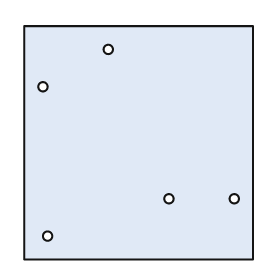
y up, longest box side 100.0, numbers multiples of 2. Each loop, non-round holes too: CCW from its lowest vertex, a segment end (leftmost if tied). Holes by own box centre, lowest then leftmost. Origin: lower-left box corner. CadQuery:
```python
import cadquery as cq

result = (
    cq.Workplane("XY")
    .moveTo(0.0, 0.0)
    .lineTo(98.0, 0.0)
    .lineTo(98.0, 100.0)
    .lineTo(0.0, 100.0)
    .close()
    .moveTo(10.0, 10.0)
    .circle(2.0)
    .moveTo(62.0, 26.0)
    .circle(2.0)
    .moveTo(90.0, 26.0)
    .circle(2.0)
    .moveTo(8.0, 74.0)
    .circle(2.0)
    .moveTo(36.0, 90.0)
    .circle(2.0)
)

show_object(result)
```